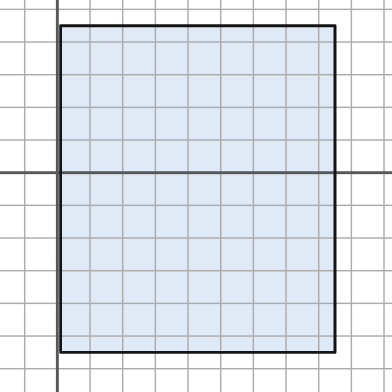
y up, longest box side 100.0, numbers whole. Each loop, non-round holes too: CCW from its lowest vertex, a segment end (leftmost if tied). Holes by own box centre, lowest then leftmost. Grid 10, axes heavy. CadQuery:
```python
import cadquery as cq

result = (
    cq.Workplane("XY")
    .moveTo(1.0, -55.0)
    .lineTo(85.0, -55.0)
    .lineTo(85.0, 45.0)
    .lineTo(1.0, 45.0)
    .close()
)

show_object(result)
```